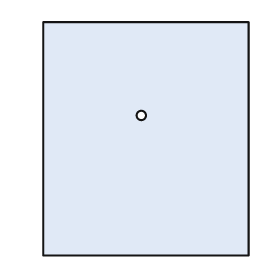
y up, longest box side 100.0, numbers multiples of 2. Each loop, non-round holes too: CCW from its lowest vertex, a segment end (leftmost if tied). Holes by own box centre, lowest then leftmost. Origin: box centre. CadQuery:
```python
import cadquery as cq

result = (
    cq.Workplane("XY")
    .moveTo(-44.0, -50.0)
    .lineTo(44.0, -50.0)
    .lineTo(44.0, 50.0)
    .lineTo(-44.0, 50.0)
    .close()
    .moveTo(-2.0, 10.0)
    .circle(2.0)
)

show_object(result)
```